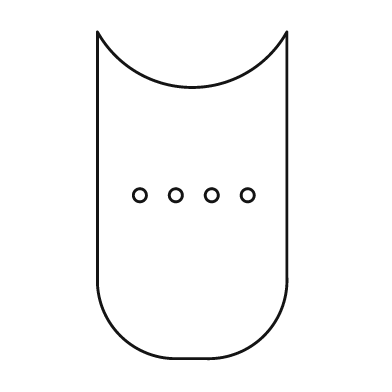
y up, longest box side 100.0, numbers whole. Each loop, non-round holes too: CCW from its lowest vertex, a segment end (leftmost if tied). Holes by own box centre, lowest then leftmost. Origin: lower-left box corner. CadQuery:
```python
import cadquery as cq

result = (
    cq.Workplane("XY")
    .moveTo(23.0, 0.0)
    .lineTo(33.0, 0.0)
    .threePointArc((51.0, 7.0), (58.0, 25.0))
    .lineTo(58.0, 100.0)
    .threePointArc((29.0, 83.0), (0.0, 100.0))
    .lineTo(0.0, 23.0)
    .threePointArc((7.0, 7.0), (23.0, 0.0))
    .close()
    .moveTo(13.0, 50.0)
    .circle(2.0)
    .moveTo(24.0, 50.0)
    .circle(2.0)
    .moveTo(35.0, 50.0)
    .circle(2.0)
    .moveTo(46.0, 50.0)
    .circle(2.0)
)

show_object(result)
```